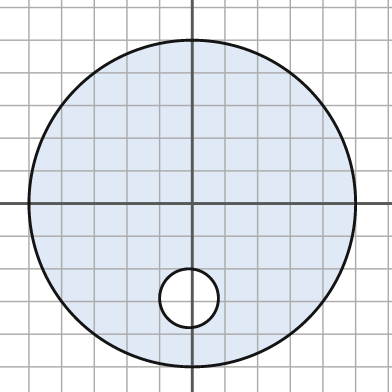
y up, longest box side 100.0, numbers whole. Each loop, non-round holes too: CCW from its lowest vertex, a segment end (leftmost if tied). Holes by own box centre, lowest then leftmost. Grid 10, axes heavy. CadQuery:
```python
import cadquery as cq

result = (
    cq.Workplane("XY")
    .moveTo(0.0, 0.0)
    .circle(50.0)
    .moveTo(-1.0, -29.0)
    .circle(9.0)
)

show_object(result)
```